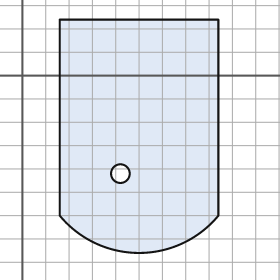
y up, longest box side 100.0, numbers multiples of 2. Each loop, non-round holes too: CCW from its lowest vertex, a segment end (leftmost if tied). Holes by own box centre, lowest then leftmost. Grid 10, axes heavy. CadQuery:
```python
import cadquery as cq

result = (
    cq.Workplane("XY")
    .moveTo(16.0, -60.0)
    .threePointArc((50.0, -76.0), (84.0, -60.0))
    .lineTo(84.0, 24.0)
    .lineTo(16.0, 24.0)
    .close()
    .moveTo(42.0, -42.0)
    .circle(4.0)
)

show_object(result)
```